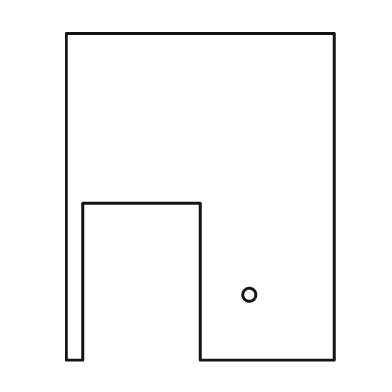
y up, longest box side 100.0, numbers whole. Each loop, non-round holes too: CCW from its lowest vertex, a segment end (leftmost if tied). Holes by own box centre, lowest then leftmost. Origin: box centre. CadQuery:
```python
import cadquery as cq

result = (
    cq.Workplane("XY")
    .moveTo(-41.0, -50.0)
    .lineTo(-36.0, -50.0)
    .lineTo(-36.0, -2.0)
    .lineTo(0.0, -2.0)
    .lineTo(0.0, -50.0)
    .lineTo(41.0, -50.0)
    .lineTo(41.0, 50.0)
    .lineTo(-41.0, 50.0)
    .close()
    .moveTo(15.0, -30.0)
    .circle(2.0)
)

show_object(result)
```